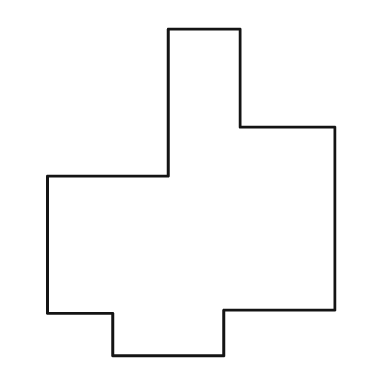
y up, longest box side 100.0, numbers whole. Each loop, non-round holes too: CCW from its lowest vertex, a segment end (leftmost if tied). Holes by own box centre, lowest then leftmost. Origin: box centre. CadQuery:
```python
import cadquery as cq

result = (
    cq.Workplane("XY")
    .moveTo(-24.0, -50.0)
    .lineTo(10.0, -50.0)
    .lineTo(10.0, -36.0)
    .lineTo(44.0, -36.0)
    .lineTo(44.0, 20.0)
    .lineTo(15.0, 20.0)
    .lineTo(15.0, 50.0)
    .lineTo(-7.0, 50.0)
    .lineTo(-7.0, 5.0)
    .lineTo(-44.0, 5.0)
    .lineTo(-44.0, -37.0)
    .lineTo(-24.0, -37.0)
    .close()
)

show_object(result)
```